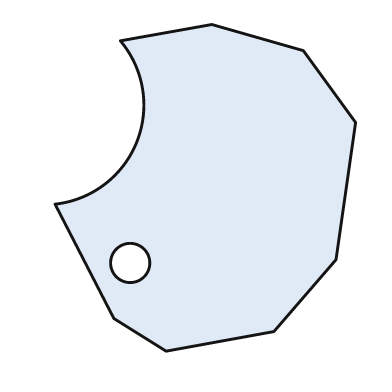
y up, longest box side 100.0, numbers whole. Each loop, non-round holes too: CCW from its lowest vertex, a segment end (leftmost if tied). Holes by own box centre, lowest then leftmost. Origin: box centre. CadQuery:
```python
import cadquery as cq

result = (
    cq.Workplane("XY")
    .moveTo(-12.0, -50.0)
    .lineTo(21.0, -44.0)
    .lineTo(40.0, -22.0)
    .lineTo(46.0, 20.0)
    .lineTo(30.0, 42.0)
    .lineTo(2.0, 50.0)
    .lineTo(-26.0, 45.0)
    .threePointArc((-21.0, 14.0), (-46.0, -5.0))
    .lineTo(-28.0, -40.0)
    .close()
    .moveTo(-23.0, -23.0)
    .circle(6.0)
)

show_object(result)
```